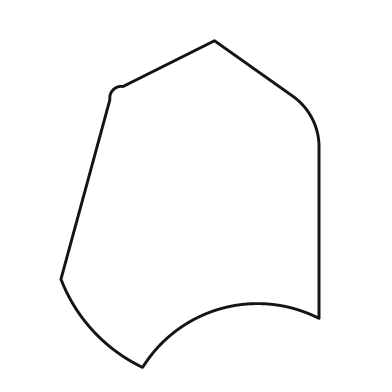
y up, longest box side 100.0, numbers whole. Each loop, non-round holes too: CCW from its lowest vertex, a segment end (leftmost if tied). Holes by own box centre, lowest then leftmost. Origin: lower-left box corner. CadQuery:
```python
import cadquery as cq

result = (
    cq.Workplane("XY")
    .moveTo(25.0, 0.0)
    .threePointArc((49.0, 18.0), (79.0, 15.0))
    .lineTo(79.0, 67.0)
    .threePointArc((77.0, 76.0), (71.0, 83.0))
    .lineTo(47.0, 100.0)
    .lineTo(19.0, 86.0)
    .threePointArc((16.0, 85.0), (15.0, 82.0))
    .lineTo(0.0, 27.0)
    .threePointArc((10.0, 11.0), (25.0, 0.0))
    .close()
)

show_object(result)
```